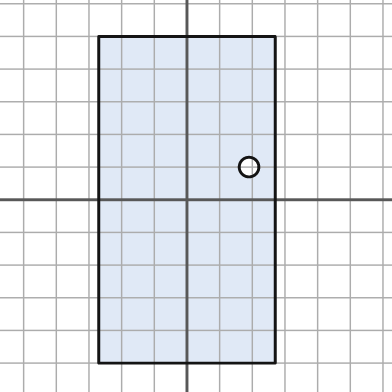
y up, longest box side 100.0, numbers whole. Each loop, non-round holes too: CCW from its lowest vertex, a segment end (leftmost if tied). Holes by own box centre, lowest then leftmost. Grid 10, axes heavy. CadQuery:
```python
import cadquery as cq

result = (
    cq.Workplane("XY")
    .moveTo(-27.0, -50.0)
    .lineTo(27.0, -50.0)
    .lineTo(27.0, 50.0)
    .lineTo(-27.0, 50.0)
    .close()
    .moveTo(19.0, 10.0)
    .circle(3.0)
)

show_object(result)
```